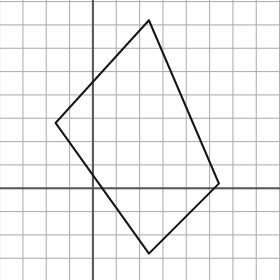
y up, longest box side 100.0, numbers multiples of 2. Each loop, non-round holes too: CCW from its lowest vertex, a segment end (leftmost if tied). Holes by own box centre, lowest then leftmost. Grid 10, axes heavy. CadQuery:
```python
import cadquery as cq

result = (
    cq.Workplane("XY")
    .moveTo(24.0, -28.0)
    .lineTo(54.0, 2.0)
    .lineTo(24.0, 72.0)
    .lineTo(-16.0, 28.0)
    .close()
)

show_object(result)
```